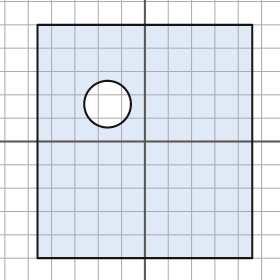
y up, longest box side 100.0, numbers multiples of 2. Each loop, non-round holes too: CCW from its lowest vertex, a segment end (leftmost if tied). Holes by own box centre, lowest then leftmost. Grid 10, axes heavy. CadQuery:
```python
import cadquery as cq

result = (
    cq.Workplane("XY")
    .moveTo(-46.0, -50.0)
    .lineTo(46.0, -50.0)
    .lineTo(46.0, 50.0)
    .lineTo(-46.0, 50.0)
    .close()
    .moveTo(-16.0, 16.0)
    .circle(10.0)
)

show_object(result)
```